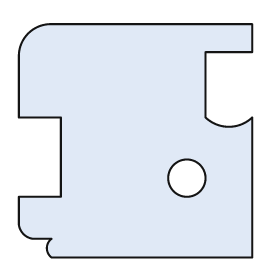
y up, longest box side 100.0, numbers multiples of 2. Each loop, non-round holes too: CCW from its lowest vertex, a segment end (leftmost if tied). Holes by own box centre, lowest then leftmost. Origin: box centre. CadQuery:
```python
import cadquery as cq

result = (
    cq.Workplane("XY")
    .moveTo(-36.0, -50.0)
    .lineTo(50.0, -50.0)
    .lineTo(50.0, 10.0)
    .threePointArc((40.0, 6.0), (30.0, 10.0))
    .lineTo(30.0, 38.0)
    .lineTo(50.0, 38.0)
    .lineTo(50.0, 50.0)
    .lineTo(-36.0, 50.0)
    .threePointArc((-46.0, 46.0), (-50.0, 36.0))
    .lineTo(-50.0, 10.0)
    .lineTo(-32.0, 10.0)
    .lineTo(-32.0, -24.0)
    .lineTo(-50.0, -24.0)
    .lineTo(-50.0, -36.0)
    .threePointArc((-48.0, -40.0), (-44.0, -42.0))
    .lineTo(-36.0, -42.0)
    .threePointArc((-38.0, -46.0), (-36.0, -50.0))
    .close()
    .moveTo(22.0, -16.0)
    .circle(8.0)
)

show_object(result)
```